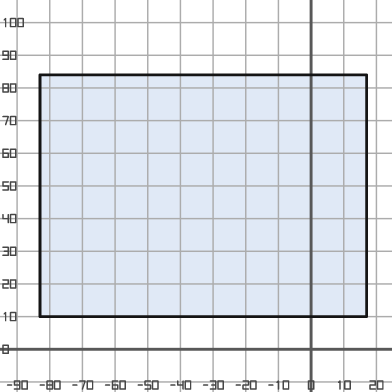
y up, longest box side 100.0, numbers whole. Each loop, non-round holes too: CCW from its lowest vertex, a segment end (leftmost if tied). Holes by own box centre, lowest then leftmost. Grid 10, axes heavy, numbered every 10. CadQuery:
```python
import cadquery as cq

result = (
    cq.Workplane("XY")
    .moveTo(-83.0, 10.0)
    .lineTo(17.0, 10.0)
    .lineTo(17.0, 84.0)
    .lineTo(-83.0, 84.0)
    .close()
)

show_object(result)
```